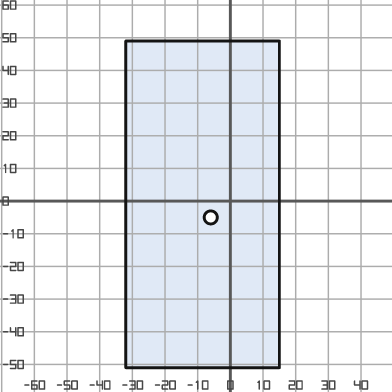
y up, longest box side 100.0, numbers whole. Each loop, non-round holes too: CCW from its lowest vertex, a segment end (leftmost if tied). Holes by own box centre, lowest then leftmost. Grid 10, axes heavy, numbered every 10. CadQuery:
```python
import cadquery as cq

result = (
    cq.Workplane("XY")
    .moveTo(-32.0, -51.0)
    .lineTo(15.0, -51.0)
    .lineTo(15.0, 49.0)
    .lineTo(-32.0, 49.0)
    .close()
    .moveTo(-6.0, -5.0)
    .circle(2.0)
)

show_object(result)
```